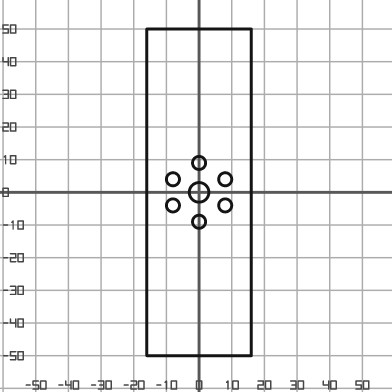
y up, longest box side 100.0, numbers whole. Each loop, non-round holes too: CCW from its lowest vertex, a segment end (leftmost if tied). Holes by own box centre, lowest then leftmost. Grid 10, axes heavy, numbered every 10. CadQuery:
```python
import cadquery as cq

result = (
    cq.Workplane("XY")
    .moveTo(-16.0, -50.0)
    .lineTo(16.0, -50.0)
    .lineTo(16.0, 50.0)
    .lineTo(-16.0, 50.0)
    .close()
    .moveTo(0.0, -9.0)
    .circle(2.0)
    .moveTo(-8.0, -4.0)
    .circle(2.0)
    .moveTo(8.0, -4.0)
    .circle(2.0)
    .moveTo(0.0, 0.0)
    .circle(3.0)
    .moveTo(-8.0, 4.0)
    .circle(2.0)
    .moveTo(8.0, 4.0)
    .circle(2.0)
    .moveTo(0.0, 9.0)
    .circle(2.0)
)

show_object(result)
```